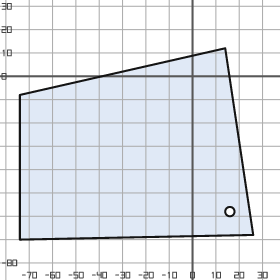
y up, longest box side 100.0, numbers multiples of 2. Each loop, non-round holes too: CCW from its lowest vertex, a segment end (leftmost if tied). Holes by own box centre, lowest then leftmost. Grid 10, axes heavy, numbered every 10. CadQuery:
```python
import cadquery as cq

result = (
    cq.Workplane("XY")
    .moveTo(-74.0, -70.0)
    .lineTo(26.0, -68.0)
    .lineTo(14.0, 12.0)
    .lineTo(-74.0, -8.0)
    .close()
    .moveTo(16.0, -58.0)
    .circle(2.0)
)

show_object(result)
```